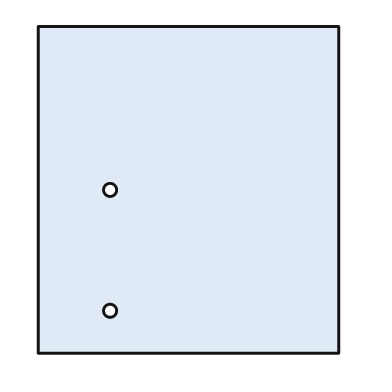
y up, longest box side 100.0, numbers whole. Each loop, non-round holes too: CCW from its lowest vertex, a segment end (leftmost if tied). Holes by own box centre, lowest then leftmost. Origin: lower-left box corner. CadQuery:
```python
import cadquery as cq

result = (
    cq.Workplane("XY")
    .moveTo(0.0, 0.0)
    .lineTo(92.0, 0.0)
    .lineTo(92.0, 100.0)
    .lineTo(0.0, 100.0)
    .close()
    .moveTo(22.0, 13.0)
    .circle(2.0)
    .moveTo(22.0, 50.0)
    .circle(2.0)
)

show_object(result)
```